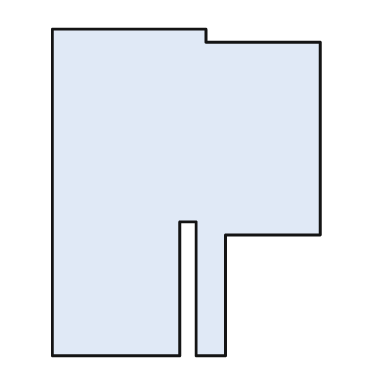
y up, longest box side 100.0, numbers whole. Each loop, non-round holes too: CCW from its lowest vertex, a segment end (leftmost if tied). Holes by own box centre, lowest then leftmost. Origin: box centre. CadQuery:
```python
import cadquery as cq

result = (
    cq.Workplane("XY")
    .moveTo(-41.0, -50.0)
    .lineTo(-2.0, -50.0)
    .lineTo(-2.0, -9.0)
    .lineTo(3.0, -9.0)
    .lineTo(3.0, -50.0)
    .lineTo(12.0, -50.0)
    .lineTo(12.0, -13.0)
    .lineTo(41.0, -13.0)
    .lineTo(41.0, 46.0)
    .lineTo(6.0, 46.0)
    .lineTo(6.0, 50.0)
    .lineTo(-41.0, 50.0)
    .close()
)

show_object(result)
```